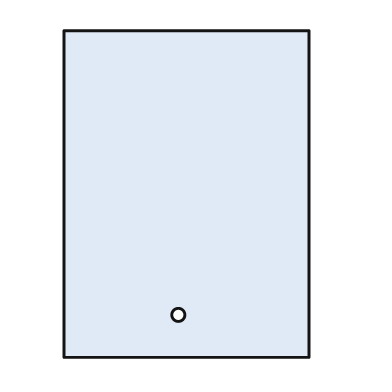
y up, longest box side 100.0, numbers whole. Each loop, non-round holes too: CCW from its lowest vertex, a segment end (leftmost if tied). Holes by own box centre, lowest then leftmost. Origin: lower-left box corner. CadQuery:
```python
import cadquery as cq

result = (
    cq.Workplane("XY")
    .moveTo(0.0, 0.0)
    .lineTo(75.0, 0.0)
    .lineTo(75.0, 100.0)
    .lineTo(0.0, 100.0)
    .close()
    .moveTo(35.0, 13.0)
    .circle(2.0)
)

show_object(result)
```